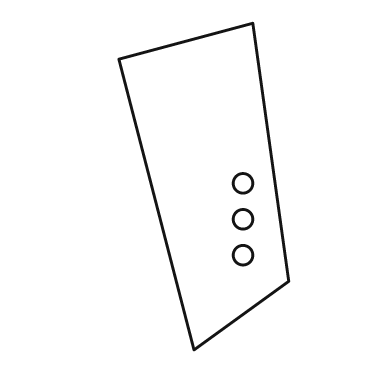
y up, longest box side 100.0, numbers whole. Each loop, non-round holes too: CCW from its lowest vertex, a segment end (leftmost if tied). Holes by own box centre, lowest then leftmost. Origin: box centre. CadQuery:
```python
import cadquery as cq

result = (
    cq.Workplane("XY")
    .moveTo(-3.0, -50.0)
    .lineTo(26.0, -29.0)
    .lineTo(15.0, 50.0)
    .lineTo(-26.0, 39.0)
    .close()
    .moveTo(12.0, -21.0)
    .circle(3.0)
    .moveTo(12.0, -10.0)
    .circle(3.0)
    .moveTo(12.0, 1.0)
    .circle(3.0)
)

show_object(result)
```